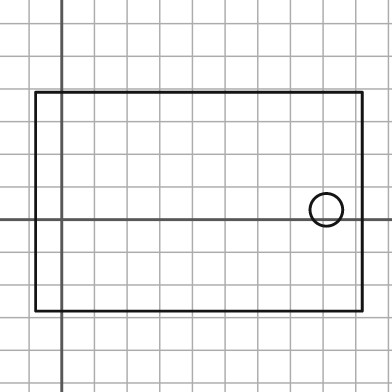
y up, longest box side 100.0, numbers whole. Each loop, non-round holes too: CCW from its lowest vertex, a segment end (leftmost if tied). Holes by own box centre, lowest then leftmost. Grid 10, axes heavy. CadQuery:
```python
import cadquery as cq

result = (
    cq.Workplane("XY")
    .moveTo(-8.0, -28.0)
    .lineTo(92.0, -28.0)
    .lineTo(92.0, 39.0)
    .lineTo(-8.0, 39.0)
    .close()
    .moveTo(81.0, 3.0)
    .circle(5.0)
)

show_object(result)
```